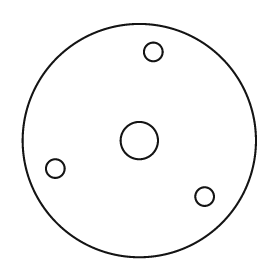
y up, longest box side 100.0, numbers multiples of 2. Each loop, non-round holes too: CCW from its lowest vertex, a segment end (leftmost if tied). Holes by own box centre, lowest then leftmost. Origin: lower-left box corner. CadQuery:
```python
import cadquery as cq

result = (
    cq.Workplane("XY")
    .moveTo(50.0, 50.0)
    .circle(50.0)
    .moveTo(78.0, 26.0)
    .circle(4.0)
    .moveTo(14.0, 38.0)
    .circle(4.0)
    .moveTo(50.0, 50.0)
    .circle(8.0)
    .moveTo(56.0, 88.0)
    .circle(4.0)
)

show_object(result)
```